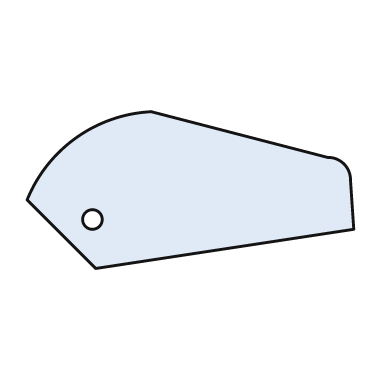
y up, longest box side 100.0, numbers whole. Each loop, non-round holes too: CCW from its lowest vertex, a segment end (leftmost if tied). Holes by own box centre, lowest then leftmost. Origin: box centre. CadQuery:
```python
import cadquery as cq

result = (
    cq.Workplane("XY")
    .moveTo(-29.0, -24.0)
    .lineTo(50.0, -12.0)
    .lineTo(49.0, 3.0)
    .threePointArc((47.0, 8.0), (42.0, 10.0))
    .lineTo(-12.0, 24.0)
    .threePointArc((-35.0, 16.0), (-50.0, -3.0))
    .close()
    .moveTo(-30.0, -9.0)
    .circle(3.0)
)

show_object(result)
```